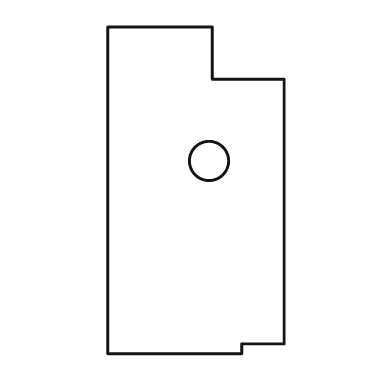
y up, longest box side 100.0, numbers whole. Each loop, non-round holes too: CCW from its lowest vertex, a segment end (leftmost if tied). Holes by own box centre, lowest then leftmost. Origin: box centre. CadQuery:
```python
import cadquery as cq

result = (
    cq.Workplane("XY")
    .moveTo(-27.0, -50.0)
    .lineTo(14.0, -50.0)
    .lineTo(14.0, -47.0)
    .lineTo(27.0, -47.0)
    .lineTo(27.0, 34.0)
    .lineTo(5.0, 34.0)
    .lineTo(5.0, 50.0)
    .lineTo(-27.0, 50.0)
    .close()
    .moveTo(4.0, 9.0)
    .circle(6.0)
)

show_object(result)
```